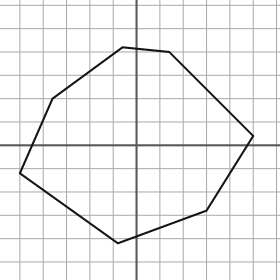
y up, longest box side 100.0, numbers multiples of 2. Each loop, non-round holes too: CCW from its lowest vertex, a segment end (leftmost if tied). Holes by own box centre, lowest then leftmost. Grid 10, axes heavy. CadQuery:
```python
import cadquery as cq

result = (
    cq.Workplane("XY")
    .moveTo(-8.0, -42.0)
    .lineTo(30.0, -28.0)
    .lineTo(50.0, 4.0)
    .lineTo(14.0, 40.0)
    .lineTo(-6.0, 42.0)
    .lineTo(-36.0, 20.0)
    .lineTo(-50.0, -12.0)
    .close()
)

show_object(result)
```